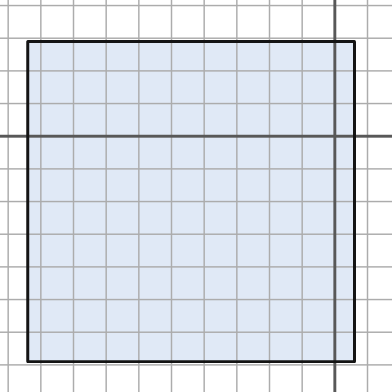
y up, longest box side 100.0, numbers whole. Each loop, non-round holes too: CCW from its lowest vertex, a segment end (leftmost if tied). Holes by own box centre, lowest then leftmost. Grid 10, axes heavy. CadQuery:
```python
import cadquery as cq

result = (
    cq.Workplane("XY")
    .moveTo(-94.0, -69.0)
    .lineTo(6.0, -69.0)
    .lineTo(6.0, 29.0)
    .lineTo(-94.0, 29.0)
    .close()
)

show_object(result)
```